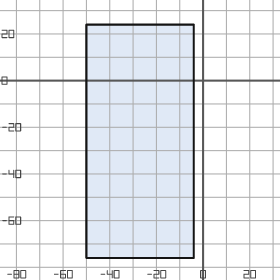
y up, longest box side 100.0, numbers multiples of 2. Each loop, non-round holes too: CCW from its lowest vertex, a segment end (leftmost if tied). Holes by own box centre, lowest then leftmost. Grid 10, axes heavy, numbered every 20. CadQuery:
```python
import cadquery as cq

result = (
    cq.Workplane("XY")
    .moveTo(-50.0, -76.0)
    .lineTo(-4.0, -76.0)
    .lineTo(-4.0, 24.0)
    .lineTo(-50.0, 24.0)
    .close()
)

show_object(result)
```